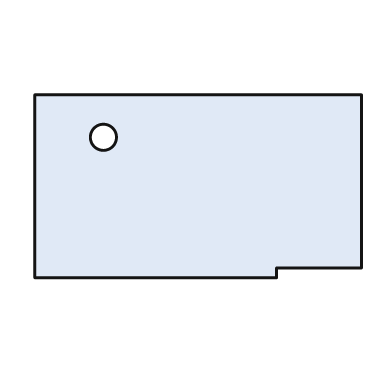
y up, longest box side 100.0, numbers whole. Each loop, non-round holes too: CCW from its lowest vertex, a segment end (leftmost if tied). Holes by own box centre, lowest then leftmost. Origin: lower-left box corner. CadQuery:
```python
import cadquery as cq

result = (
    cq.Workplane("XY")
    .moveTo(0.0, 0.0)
    .lineTo(74.0, 0.0)
    .lineTo(74.0, 3.0)
    .lineTo(100.0, 3.0)
    .lineTo(100.0, 56.0)
    .lineTo(0.0, 56.0)
    .close()
    .moveTo(21.0, 43.0)
    .circle(4.0)
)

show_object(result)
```